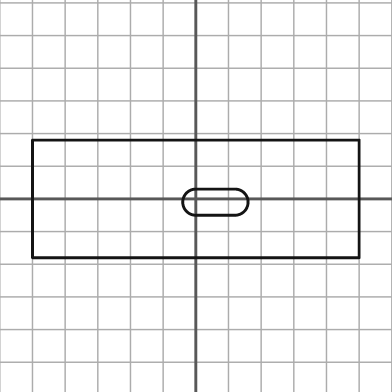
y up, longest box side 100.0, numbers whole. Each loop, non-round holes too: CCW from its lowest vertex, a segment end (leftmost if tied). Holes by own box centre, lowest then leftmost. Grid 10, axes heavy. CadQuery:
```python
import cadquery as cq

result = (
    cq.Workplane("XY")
    .moveTo(-50.0, -18.0)
    .lineTo(50.0, -18.0)
    .lineTo(50.0, 18.0)
    .lineTo(-50.0, 18.0)
    .close()
    .moveTo(0.0, -5.0)
    .lineTo(12.0, -5.0)
    .threePointArc((16.0, -1.0), (12.0, 3.0))
    .lineTo(0.0, 3.0)
    .threePointArc((-4.0, -1.0), (0.0, -5.0))
    .close()
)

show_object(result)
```